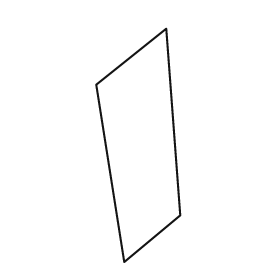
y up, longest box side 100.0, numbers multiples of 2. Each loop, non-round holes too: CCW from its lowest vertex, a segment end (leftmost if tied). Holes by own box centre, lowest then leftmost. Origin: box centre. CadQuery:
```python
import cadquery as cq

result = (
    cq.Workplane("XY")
    .moveTo(-6.0, -50.0)
    .lineTo(18.0, -30.0)
    .lineTo(12.0, 50.0)
    .lineTo(-18.0, 26.0)
    .close()
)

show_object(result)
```